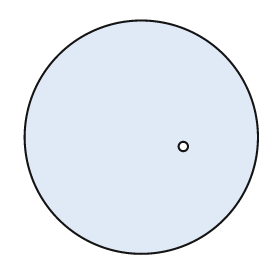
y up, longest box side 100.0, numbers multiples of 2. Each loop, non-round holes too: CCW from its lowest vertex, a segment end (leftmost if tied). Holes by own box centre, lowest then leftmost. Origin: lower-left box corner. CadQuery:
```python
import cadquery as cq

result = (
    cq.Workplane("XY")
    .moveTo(50.0, 50.0)
    .circle(50.0)
    .moveTo(68.0, 46.0)
    .circle(2.0)
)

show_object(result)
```